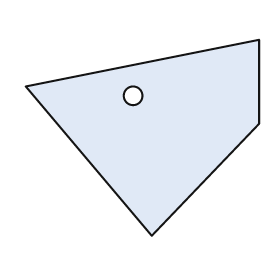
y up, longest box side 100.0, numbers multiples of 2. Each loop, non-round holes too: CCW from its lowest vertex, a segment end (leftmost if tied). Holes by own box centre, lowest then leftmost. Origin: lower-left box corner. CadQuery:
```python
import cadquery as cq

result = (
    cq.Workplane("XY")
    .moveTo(54.0, 0.0)
    .lineTo(100.0, 48.0)
    .lineTo(100.0, 84.0)
    .lineTo(0.0, 64.0)
    .close()
    .moveTo(46.0, 60.0)
    .circle(4.0)
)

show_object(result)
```